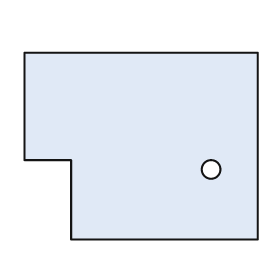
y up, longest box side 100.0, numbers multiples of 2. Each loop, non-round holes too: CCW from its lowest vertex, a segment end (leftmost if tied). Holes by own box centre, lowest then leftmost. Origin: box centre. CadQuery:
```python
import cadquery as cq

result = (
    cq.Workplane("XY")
    .moveTo(-30.0, -40.0)
    .lineTo(50.0, -40.0)
    .lineTo(50.0, 40.0)
    .lineTo(-50.0, 40.0)
    .lineTo(-50.0, -6.0)
    .lineTo(-30.0, -6.0)
    .close()
    .moveTo(30.0, -10.0)
    .circle(4.0)
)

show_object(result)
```